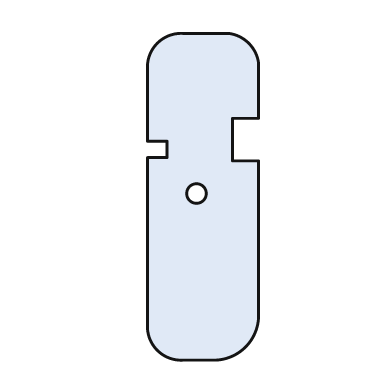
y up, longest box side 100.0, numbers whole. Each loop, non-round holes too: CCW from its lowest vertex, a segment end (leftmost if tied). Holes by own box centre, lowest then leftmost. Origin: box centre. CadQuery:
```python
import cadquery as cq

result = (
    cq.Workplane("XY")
    .moveTo(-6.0, -50.0)
    .lineTo(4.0, -50.0)
    .threePointArc((13.0, -46.0), (17.0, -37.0))
    .lineTo(17.0, 11.0)
    .lineTo(9.0, 11.0)
    .lineTo(9.0, 24.0)
    .lineTo(17.0, 24.0)
    .lineTo(17.0, 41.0)
    .threePointArc((14.0, 47.0), (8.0, 50.0))
    .lineTo(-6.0, 50.0)
    .threePointArc((-14.0, 47.0), (-17.0, 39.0))
    .lineTo(-17.0, 17.0)
    .lineTo(-11.0, 17.0)
    .lineTo(-11.0, 12.0)
    .lineTo(-17.0, 12.0)
    .lineTo(-17.0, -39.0)
    .threePointArc((-14.0, -47.0), (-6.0, -50.0))
    .close()
    .moveTo(-2.0, 1.0)
    .circle(3.0)
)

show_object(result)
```